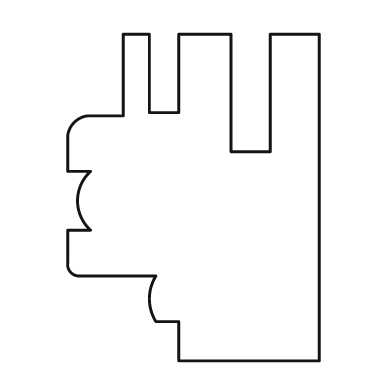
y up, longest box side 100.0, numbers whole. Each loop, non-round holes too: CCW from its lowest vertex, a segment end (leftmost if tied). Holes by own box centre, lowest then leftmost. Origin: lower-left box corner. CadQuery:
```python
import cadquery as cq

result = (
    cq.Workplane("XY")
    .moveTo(34.0, 0.0)
    .lineTo(77.0, 0.0)
    .lineTo(77.0, 100.0)
    .lineTo(62.0, 100.0)
    .lineTo(62.0, 64.0)
    .lineTo(50.0, 64.0)
    .lineTo(50.0, 100.0)
    .lineTo(34.0, 100.0)
    .lineTo(34.0, 76.0)
    .lineTo(25.0, 76.0)
    .lineTo(25.0, 100.0)
    .lineTo(17.0, 100.0)
    .lineTo(17.0, 75.0)
    .lineTo(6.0, 75.0)
    .threePointArc((2.0, 73.0), (0.0, 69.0))
    .lineTo(0.0, 58.0)
    .lineTo(7.0, 58.0)
    .threePointArc((3.0, 49.0), (7.0, 40.0))
    .lineTo(0.0, 40.0)
    .lineTo(0.0, 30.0)
    .threePointArc((1.0, 27.0), (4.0, 26.0))
    .lineTo(27.0, 26.0)
    .threePointArc((25.0, 19.0), (27.0, 12.0))
    .lineTo(34.0, 12.0)
    .close()
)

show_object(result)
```